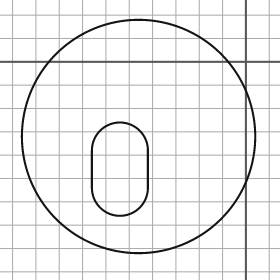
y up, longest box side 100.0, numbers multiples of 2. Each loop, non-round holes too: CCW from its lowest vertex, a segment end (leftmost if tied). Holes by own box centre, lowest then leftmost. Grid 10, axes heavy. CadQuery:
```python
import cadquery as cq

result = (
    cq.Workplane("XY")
    .moveTo(-46.0, -32.0)
    .circle(50.0)
    .moveTo(-66.0, -54.0)
    .threePointArc((-54.0, -66.0), (-42.0, -54.0))
    .lineTo(-42.0, -38.0)
    .threePointArc((-54.0, -26.0), (-66.0, -38.0))
    .close()
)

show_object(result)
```